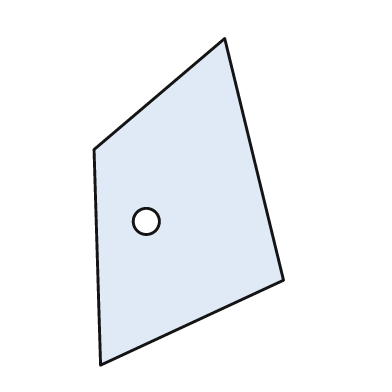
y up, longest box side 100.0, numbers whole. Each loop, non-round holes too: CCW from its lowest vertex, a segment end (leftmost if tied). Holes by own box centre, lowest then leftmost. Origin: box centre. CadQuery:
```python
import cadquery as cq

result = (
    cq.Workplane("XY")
    .moveTo(-27.0, -50.0)
    .lineTo(29.0, -24.0)
    .lineTo(11.0, 50.0)
    .lineTo(-29.0, 16.0)
    .close()
    .moveTo(-13.0, -6.0)
    .circle(4.0)
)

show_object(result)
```